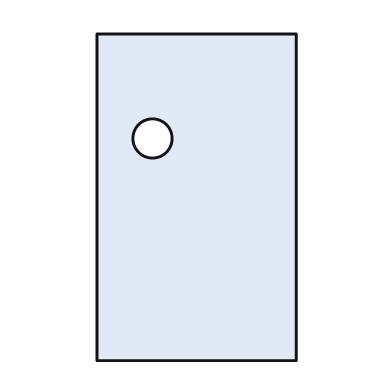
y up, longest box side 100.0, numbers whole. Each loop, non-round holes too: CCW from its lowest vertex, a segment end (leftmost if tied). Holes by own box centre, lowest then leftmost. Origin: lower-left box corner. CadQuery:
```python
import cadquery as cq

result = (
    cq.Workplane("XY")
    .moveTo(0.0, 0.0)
    .lineTo(61.0, 0.0)
    .lineTo(61.0, 100.0)
    .lineTo(0.0, 100.0)
    .close()
    .moveTo(17.0, 68.0)
    .circle(6.0)
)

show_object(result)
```